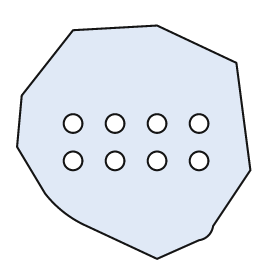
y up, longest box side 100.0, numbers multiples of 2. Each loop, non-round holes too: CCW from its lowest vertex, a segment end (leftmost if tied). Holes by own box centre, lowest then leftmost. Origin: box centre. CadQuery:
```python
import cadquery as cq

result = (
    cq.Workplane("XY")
    .moveTo(10.0, -50.0)
    .lineTo(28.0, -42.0)
    .threePointArc((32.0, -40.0), (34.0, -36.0))
    .lineTo(50.0, -12.0)
    .lineTo(44.0, 34.0)
    .lineTo(10.0, 50.0)
    .lineTo(-26.0, 48.0)
    .lineTo(-48.0, 20.0)
    .lineTo(-50.0, -2.0)
    .lineTo(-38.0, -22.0)
    .threePointArc((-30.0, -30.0), (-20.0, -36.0))
    .close()
    .moveTo(-26.0, -8.0)
    .circle(4.0)
    .moveTo(-8.0, -8.0)
    .circle(4.0)
    .moveTo(10.0, -8.0)
    .circle(4.0)
    .moveTo(28.0, -8.0)
    .circle(4.0)
    .moveTo(-26.0, 8.0)
    .circle(4.0)
    .moveTo(-8.0, 8.0)
    .circle(4.0)
    .moveTo(10.0, 8.0)
    .circle(4.0)
    .moveTo(28.0, 8.0)
    .circle(4.0)
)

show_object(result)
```